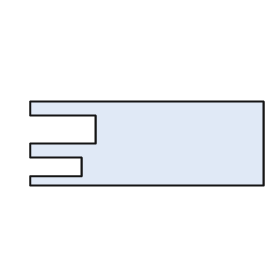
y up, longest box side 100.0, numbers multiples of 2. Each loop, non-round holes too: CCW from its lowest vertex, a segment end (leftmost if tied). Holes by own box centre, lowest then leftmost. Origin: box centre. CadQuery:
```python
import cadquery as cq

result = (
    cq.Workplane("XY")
    .moveTo(-50.0, -18.0)
    .lineTo(50.0, -18.0)
    .lineTo(50.0, 18.0)
    .lineTo(-50.0, 18.0)
    .lineTo(-50.0, 12.0)
    .lineTo(-22.0, 12.0)
    .lineTo(-22.0, 0.0)
    .lineTo(-50.0, 0.0)
    .lineTo(-50.0, -6.0)
    .lineTo(-28.0, -6.0)
    .lineTo(-28.0, -14.0)
    .lineTo(-50.0, -14.0)
    .close()
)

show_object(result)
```